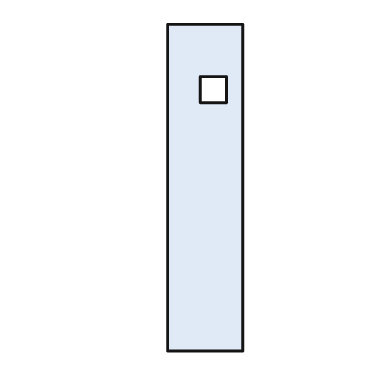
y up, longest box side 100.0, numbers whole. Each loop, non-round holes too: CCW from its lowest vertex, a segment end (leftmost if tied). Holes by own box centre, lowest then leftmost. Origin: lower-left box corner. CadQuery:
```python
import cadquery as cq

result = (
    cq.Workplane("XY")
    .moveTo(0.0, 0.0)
    .lineTo(23.0, 0.0)
    .lineTo(23.0, 100.0)
    .lineTo(0.0, 100.0)
    .close()
    .moveTo(10.0, 76.0)
    .lineTo(18.0, 76.0)
    .lineTo(18.0, 84.0)
    .lineTo(10.0, 84.0)
    .close()
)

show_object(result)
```